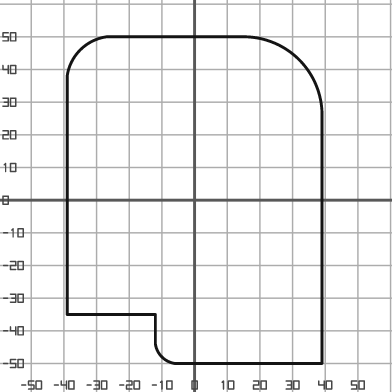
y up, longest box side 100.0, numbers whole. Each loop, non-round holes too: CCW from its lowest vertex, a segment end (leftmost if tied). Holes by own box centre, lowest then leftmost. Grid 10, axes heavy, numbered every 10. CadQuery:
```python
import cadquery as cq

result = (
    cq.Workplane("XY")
    .moveTo(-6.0, -50.0)
    .lineTo(39.0, -50.0)
    .lineTo(39.0, 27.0)
    .threePointArc((32.0, 43.0), (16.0, 50.0))
    .lineTo(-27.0, 50.0)
    .threePointArc((-35.0, 46.0), (-39.0, 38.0))
    .lineTo(-39.0, -35.0)
    .lineTo(-12.0, -35.0)
    .lineTo(-12.0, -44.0)
    .threePointArc((-10.0, -48.0), (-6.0, -50.0))
    .close()
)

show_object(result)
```